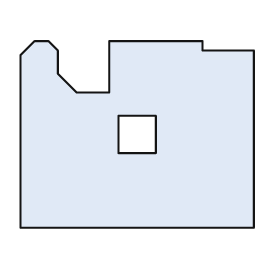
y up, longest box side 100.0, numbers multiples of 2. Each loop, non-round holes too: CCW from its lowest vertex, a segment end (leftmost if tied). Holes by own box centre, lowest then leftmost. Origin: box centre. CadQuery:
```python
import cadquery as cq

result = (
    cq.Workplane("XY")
    .moveTo(-50.0, -40.0)
    .lineTo(50.0, -40.0)
    .lineTo(50.0, 36.0)
    .lineTo(28.0, 36.0)
    .lineTo(28.0, 40.0)
    .lineTo(-12.0, 40.0)
    .lineTo(-12.0, 18.0)
    .lineTo(-26.0, 18.0)
    .lineTo(-34.0, 26.0)
    .lineTo(-34.0, 36.0)
    .lineTo(-38.0, 40.0)
    .lineTo(-44.0, 40.0)
    .lineTo(-50.0, 34.0)
    .close()
    .moveTo(-8.0, -8.0)
    .lineTo(8.0, -8.0)
    .lineTo(8.0, 8.0)
    .lineTo(-8.0, 8.0)
    .close()
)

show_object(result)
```